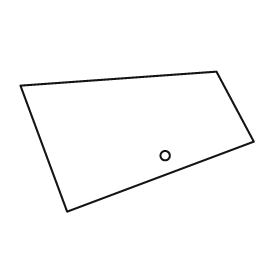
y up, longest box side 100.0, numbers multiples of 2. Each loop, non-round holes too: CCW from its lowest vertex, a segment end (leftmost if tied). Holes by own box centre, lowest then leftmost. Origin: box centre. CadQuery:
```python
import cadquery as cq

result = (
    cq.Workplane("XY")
    .moveTo(-30.0, -30.0)
    .lineTo(50.0, 0.0)
    .lineTo(34.0, 30.0)
    .lineTo(-50.0, 24.0)
    .close()
    .moveTo(12.0, -6.0)
    .circle(2.0)
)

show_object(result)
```